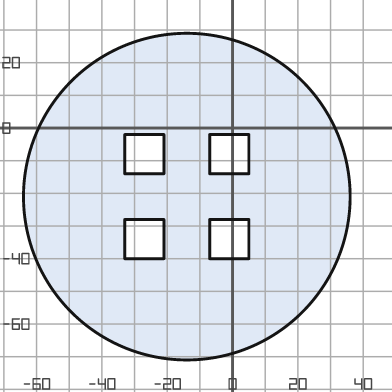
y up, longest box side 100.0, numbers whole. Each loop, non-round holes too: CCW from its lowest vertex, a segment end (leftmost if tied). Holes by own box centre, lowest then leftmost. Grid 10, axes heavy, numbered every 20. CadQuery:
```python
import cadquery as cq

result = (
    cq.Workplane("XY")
    .moveTo(-14.0, -21.0)
    .circle(50.0)
    .moveTo(-33.0, -40.0)
    .lineTo(-21.0, -40.0)
    .lineTo(-21.0, -28.0)
    .lineTo(-33.0, -28.0)
    .close()
    .moveTo(-7.0, -40.0)
    .lineTo(5.0, -40.0)
    .lineTo(5.0, -28.0)
    .lineTo(-7.0, -28.0)
    .close()
    .moveTo(-33.0, -14.0)
    .lineTo(-21.0, -14.0)
    .lineTo(-21.0, -2.0)
    .lineTo(-33.0, -2.0)
    .close()
    .moveTo(-7.0, -14.0)
    .lineTo(5.0, -14.0)
    .lineTo(5.0, -2.0)
    .lineTo(-7.0, -2.0)
    .close()
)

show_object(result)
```